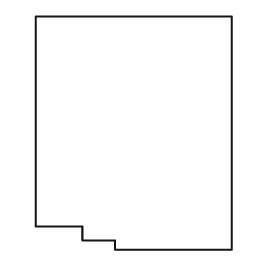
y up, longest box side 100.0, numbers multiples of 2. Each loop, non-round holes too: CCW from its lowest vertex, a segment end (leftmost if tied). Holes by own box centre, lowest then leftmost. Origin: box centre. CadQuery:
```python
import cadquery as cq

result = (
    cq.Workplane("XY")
    .moveTo(-8.0, -50.0)
    .lineTo(42.0, -50.0)
    .lineTo(42.0, 50.0)
    .lineTo(-42.0, 50.0)
    .lineTo(-42.0, -40.0)
    .lineTo(-22.0, -40.0)
    .lineTo(-22.0, -46.0)
    .lineTo(-8.0, -46.0)
    .close()
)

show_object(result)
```